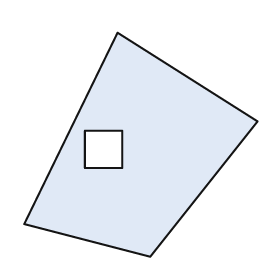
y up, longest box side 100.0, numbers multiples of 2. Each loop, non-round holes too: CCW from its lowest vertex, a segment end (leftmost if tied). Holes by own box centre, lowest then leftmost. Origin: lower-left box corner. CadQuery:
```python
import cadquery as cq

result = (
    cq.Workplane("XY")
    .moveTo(54.0, 0.0)
    .lineTo(100.0, 58.0)
    .lineTo(40.0, 96.0)
    .lineTo(0.0, 14.0)
    .close()
    .moveTo(26.0, 38.0)
    .lineTo(42.0, 38.0)
    .lineTo(42.0, 54.0)
    .lineTo(26.0, 54.0)
    .close()
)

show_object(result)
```